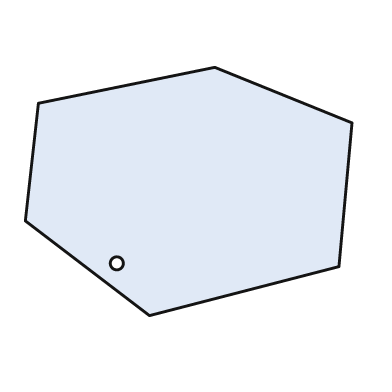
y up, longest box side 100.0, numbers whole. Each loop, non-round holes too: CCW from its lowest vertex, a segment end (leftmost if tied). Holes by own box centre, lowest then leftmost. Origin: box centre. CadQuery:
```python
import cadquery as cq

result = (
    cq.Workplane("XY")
    .moveTo(-12.0, -38.0)
    .lineTo(46.0, -23.0)
    .lineTo(50.0, 21.0)
    .lineTo(8.0, 38.0)
    .lineTo(-46.0, 27.0)
    .lineTo(-50.0, -9.0)
    .close()
    .moveTo(-22.0, -22.0)
    .circle(2.0)
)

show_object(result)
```